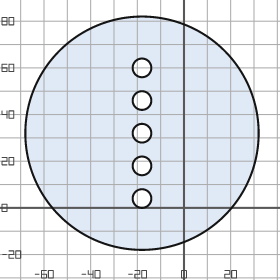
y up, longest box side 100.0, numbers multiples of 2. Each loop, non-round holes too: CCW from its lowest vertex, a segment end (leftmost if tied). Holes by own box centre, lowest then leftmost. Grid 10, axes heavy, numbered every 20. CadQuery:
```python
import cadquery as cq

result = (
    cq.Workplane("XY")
    .moveTo(-18.0, 32.0)
    .circle(50.0)
    .moveTo(-18.0, 4.0)
    .circle(4.0)
    .moveTo(-18.0, 18.0)
    .circle(4.0)
    .moveTo(-18.0, 32.0)
    .circle(4.0)
    .moveTo(-18.0, 46.0)
    .circle(4.0)
    .moveTo(-18.0, 60.0)
    .circle(4.0)
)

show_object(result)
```